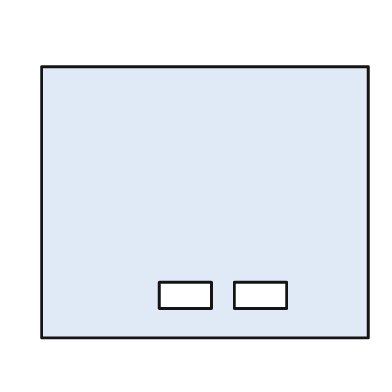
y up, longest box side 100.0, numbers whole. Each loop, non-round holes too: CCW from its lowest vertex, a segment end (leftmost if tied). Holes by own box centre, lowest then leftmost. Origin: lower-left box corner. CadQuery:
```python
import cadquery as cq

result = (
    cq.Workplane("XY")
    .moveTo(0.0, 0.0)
    .lineTo(100.0, 0.0)
    .lineTo(100.0, 83.0)
    .lineTo(0.0, 83.0)
    .close()
    .moveTo(36.0, 9.0)
    .lineTo(52.0, 9.0)
    .lineTo(52.0, 17.0)
    .lineTo(36.0, 17.0)
    .close()
    .moveTo(59.0, 9.0)
    .lineTo(75.0, 9.0)
    .lineTo(75.0, 17.0)
    .lineTo(59.0, 17.0)
    .close()
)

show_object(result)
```